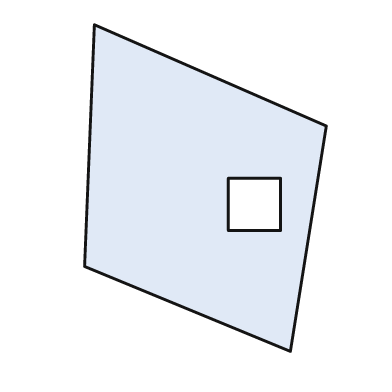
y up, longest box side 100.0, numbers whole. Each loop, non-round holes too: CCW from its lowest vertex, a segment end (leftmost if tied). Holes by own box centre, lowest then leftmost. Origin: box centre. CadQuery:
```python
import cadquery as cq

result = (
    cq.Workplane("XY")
    .moveTo(26.0, -50.0)
    .lineTo(37.0, 19.0)
    .lineTo(-34.0, 50.0)
    .lineTo(-37.0, -24.0)
    .close()
    .moveTo(7.0, -13.0)
    .lineTo(23.0, -13.0)
    .lineTo(23.0, 3.0)
    .lineTo(7.0, 3.0)
    .close()
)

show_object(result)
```